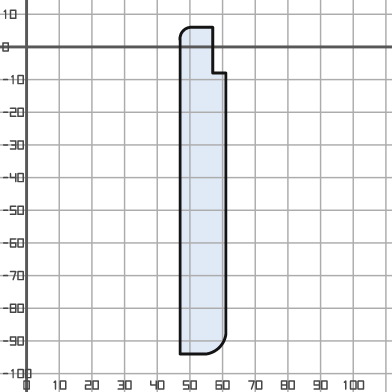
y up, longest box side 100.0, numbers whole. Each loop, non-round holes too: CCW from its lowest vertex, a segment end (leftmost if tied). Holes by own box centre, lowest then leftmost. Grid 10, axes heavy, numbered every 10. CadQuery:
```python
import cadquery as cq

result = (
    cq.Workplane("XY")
    .moveTo(47.0, -94.0)
    .lineTo(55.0, -94.0)
    .threePointArc((59.0, -92.0), (61.0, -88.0))
    .lineTo(61.0, -8.0)
    .lineTo(57.0, -8.0)
    .lineTo(57.0, 6.0)
    .lineTo(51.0, 6.0)
    .threePointArc((48.0, 5.0), (47.0, 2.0))
    .close()
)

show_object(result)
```